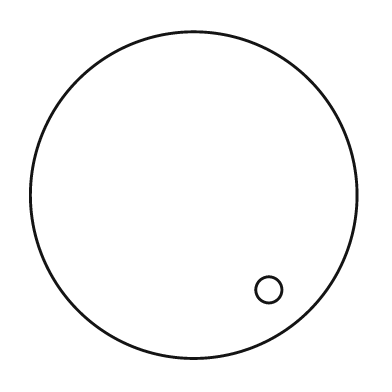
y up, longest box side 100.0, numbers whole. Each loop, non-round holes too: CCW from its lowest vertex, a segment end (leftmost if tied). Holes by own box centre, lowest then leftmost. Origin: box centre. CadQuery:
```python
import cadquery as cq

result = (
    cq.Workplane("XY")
    .moveTo(0.0, 0.0)
    .circle(50.0)
    .moveTo(23.0, -29.0)
    .circle(4.0)
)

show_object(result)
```